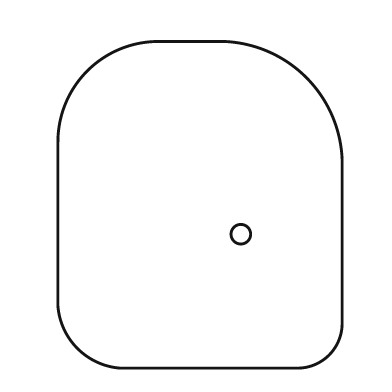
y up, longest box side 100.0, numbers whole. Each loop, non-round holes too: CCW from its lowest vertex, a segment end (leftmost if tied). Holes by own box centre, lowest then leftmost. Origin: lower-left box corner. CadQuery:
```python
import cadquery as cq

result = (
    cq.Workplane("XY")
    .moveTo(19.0, 0.0)
    .lineTo(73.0, 0.0)
    .threePointArc((83.0, 4.0), (87.0, 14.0))
    .lineTo(87.0, 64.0)
    .threePointArc((76.0, 89.0), (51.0, 100.0))
    .lineTo(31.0, 100.0)
    .threePointArc((9.0, 91.0), (0.0, 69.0))
    .lineTo(0.0, 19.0)
    .threePointArc((6.0, 6.0), (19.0, 0.0))
    .close()
    .moveTo(56.0, 41.0)
    .circle(3.0)
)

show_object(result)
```